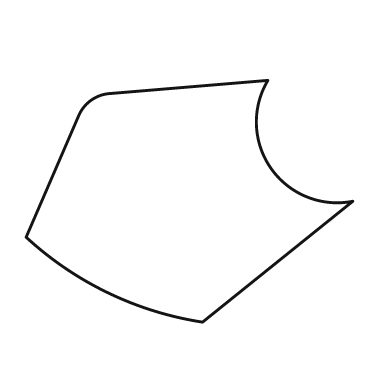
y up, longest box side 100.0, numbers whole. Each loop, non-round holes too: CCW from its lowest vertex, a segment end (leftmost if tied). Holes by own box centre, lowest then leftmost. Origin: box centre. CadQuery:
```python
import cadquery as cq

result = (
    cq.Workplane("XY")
    .moveTo(4.0, -37.0)
    .lineTo(50.0, 0.0)
    .threePointArc((25.0, 10.0), (24.0, 37.0))
    .lineTo(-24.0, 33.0)
    .threePointArc((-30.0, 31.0), (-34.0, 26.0))
    .lineTo(-50.0, -11.0)
    .threePointArc((-25.0, -28.0), (4.0, -37.0))
    .close()
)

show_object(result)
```